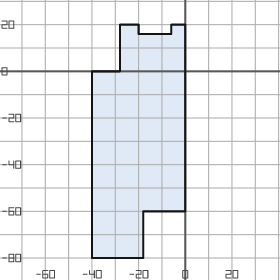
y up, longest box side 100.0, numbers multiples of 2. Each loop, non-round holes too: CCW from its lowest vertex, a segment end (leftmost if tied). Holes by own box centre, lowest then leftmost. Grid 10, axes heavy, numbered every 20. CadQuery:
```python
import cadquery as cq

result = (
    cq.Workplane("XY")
    .moveTo(-40.0, -80.0)
    .lineTo(-18.0, -80.0)
    .lineTo(-18.0, -60.0)
    .lineTo(0.0, -60.0)
    .lineTo(0.0, 20.0)
    .lineTo(-6.0, 20.0)
    .lineTo(-6.0, 16.0)
    .lineTo(-20.0, 16.0)
    .lineTo(-20.0, 20.0)
    .lineTo(-28.0, 20.0)
    .lineTo(-28.0, 0.0)
    .lineTo(-40.0, 0.0)
    .close()
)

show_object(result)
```